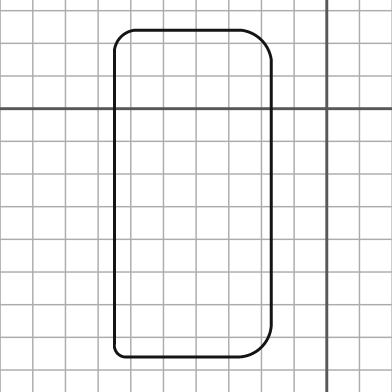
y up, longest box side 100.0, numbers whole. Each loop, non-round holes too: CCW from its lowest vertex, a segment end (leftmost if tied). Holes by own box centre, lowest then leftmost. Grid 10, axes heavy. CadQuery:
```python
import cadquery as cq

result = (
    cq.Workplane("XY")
    .moveTo(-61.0, -76.0)
    .lineTo(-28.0, -76.0)
    .threePointArc((-20.0, -73.0), (-17.0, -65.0))
    .lineTo(-17.0, 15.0)
    .threePointArc((-20.0, 21.0), (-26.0, 24.0))
    .lineTo(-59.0, 24.0)
    .threePointArc((-63.0, 22.0), (-65.0, 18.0))
    .lineTo(-65.0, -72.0)
    .threePointArc((-64.0, -75.0), (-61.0, -76.0))
    .close()
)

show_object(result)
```